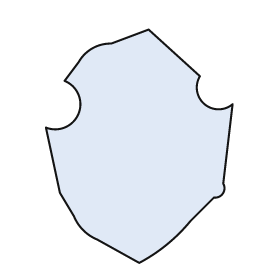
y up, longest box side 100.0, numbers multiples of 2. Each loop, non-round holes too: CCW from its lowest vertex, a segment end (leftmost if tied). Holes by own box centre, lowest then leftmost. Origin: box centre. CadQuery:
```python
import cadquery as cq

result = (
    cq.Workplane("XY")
    .moveTo(0.0, -50.0)
    .threePointArc((12.0, -42.0), (22.0, -32.0))
    .lineTo(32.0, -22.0)
    .threePointArc((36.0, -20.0), (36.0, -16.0))
    .lineTo(40.0, 18.0)
    .threePointArc((28.0, 18.0), (26.0, 30.0))
    .lineTo(4.0, 50.0)
    .lineTo(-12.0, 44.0)
    .threePointArc((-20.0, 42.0), (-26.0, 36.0))
    .lineTo(-32.0, 28.0)
    .threePointArc((-26.0, 14.0), (-40.0, 8.0))
    .lineTo(-34.0, -20.0)
    .lineTo(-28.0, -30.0)
    .threePointArc((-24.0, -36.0), (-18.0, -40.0))
    .close()
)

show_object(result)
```